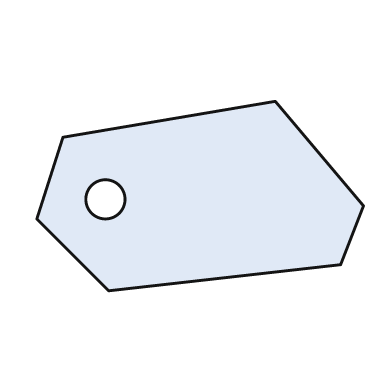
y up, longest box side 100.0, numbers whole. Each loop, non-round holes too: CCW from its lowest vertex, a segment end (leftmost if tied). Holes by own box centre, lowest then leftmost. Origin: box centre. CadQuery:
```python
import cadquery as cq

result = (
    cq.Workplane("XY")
    .moveTo(-28.0, -29.0)
    .lineTo(43.0, -21.0)
    .lineTo(50.0, -3.0)
    .lineTo(23.0, 29.0)
    .lineTo(-42.0, 18.0)
    .lineTo(-50.0, -7.0)
    .close()
    .moveTo(-29.0, -1.0)
    .circle(6.0)
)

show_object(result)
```